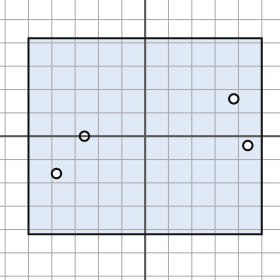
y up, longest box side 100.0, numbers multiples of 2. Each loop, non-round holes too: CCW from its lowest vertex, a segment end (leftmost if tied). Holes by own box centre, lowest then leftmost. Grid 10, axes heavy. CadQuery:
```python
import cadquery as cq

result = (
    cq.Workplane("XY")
    .moveTo(-50.0, -42.0)
    .lineTo(50.0, -42.0)
    .lineTo(50.0, 42.0)
    .lineTo(-50.0, 42.0)
    .close()
    .moveTo(-38.0, -16.0)
    .circle(2.0)
    .moveTo(44.0, -4.0)
    .circle(2.0)
    .moveTo(-26.0, 0.0)
    .circle(2.0)
    .moveTo(38.0, 16.0)
    .circle(2.0)
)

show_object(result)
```